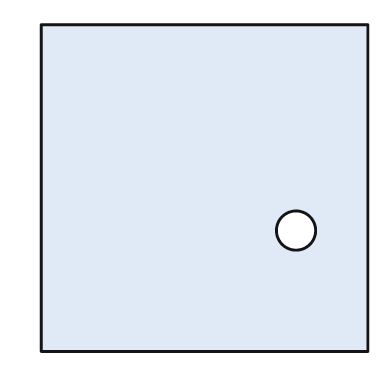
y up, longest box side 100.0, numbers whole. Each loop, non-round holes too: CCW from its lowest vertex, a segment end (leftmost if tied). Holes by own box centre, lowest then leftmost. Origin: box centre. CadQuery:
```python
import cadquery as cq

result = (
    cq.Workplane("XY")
    .moveTo(-50.0, -50.0)
    .lineTo(50.0, -50.0)
    .lineTo(50.0, 50.0)
    .lineTo(-50.0, 50.0)
    .close()
    .moveTo(28.0, -13.0)
    .circle(6.0)
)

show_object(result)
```